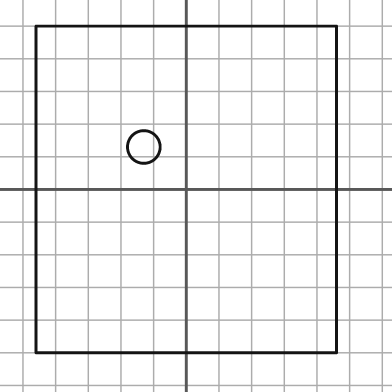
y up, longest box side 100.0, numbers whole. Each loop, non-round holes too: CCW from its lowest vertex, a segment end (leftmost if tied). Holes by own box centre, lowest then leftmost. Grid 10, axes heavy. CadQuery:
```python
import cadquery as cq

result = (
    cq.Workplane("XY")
    .moveTo(-46.0, -50.0)
    .lineTo(46.0, -50.0)
    .lineTo(46.0, 50.0)
    .lineTo(-46.0, 50.0)
    .close()
    .moveTo(-13.0, 13.0)
    .circle(5.0)
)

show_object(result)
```